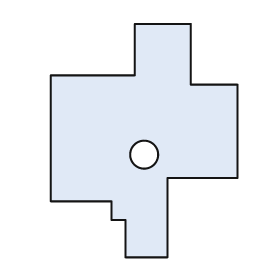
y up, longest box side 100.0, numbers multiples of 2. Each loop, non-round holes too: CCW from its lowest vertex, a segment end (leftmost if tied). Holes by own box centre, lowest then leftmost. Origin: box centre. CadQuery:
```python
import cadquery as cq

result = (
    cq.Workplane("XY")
    .moveTo(-8.0, -50.0)
    .lineTo(10.0, -50.0)
    .lineTo(10.0, -16.0)
    .lineTo(40.0, -16.0)
    .lineTo(40.0, 24.0)
    .lineTo(20.0, 24.0)
    .lineTo(20.0, 50.0)
    .lineTo(-4.0, 50.0)
    .lineTo(-4.0, 28.0)
    .lineTo(-40.0, 28.0)
    .lineTo(-40.0, -26.0)
    .lineTo(-14.0, -26.0)
    .lineTo(-14.0, -34.0)
    .lineTo(-8.0, -34.0)
    .close()
    .moveTo(0.0, -6.0)
    .circle(6.0)
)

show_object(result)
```